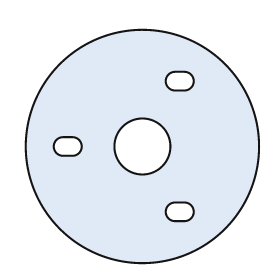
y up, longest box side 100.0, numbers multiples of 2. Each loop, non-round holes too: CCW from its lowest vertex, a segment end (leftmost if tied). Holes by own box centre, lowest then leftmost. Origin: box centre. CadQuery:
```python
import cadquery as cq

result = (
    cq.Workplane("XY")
    .moveTo(0.0, 0.0)
    .circle(50.0)
    .moveTo(14.0, -32.0)
    .lineTo(18.0, -32.0)
    .threePointArc((22.0, -28.0), (18.0, -24.0))
    .lineTo(14.0, -24.0)
    .threePointArc((10.0, -28.0), (14.0, -32.0))
    .close()
    .moveTo(-34.0, -4.0)
    .lineTo(-30.0, -4.0)
    .threePointArc((-26.0, 0.0), (-30.0, 4.0))
    .lineTo(-34.0, 4.0)
    .threePointArc((-38.0, 0.0), (-34.0, -4.0))
    .close()
    .moveTo(0.0, 0.0)
    .circle(12.0)
    .moveTo(14.0, 24.0)
    .lineTo(18.0, 24.0)
    .threePointArc((22.0, 28.0), (18.0, 32.0))
    .lineTo(14.0, 32.0)
    .threePointArc((10.0, 28.0), (14.0, 24.0))
    .close()
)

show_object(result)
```